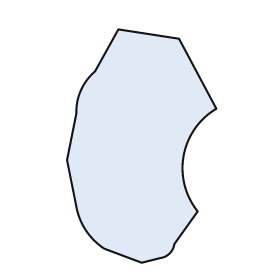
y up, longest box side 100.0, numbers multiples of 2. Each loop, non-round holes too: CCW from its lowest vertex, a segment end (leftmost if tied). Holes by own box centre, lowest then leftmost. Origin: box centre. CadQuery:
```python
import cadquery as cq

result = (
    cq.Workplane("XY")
    .moveTo(0.0, -50.0)
    .lineTo(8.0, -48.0)
    .threePointArc((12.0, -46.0), (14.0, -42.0))
    .lineTo(24.0, -28.0)
    .threePointArc((18.0, -4.0), (32.0, 16.0))
    .lineTo(16.0, 46.0)
    .lineTo(-10.0, 50.0)
    .lineTo(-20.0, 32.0)
    .threePointArc((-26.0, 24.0), (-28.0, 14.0))
    .lineTo(-32.0, -6.0)
    .lineTo(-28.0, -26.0)
    .threePointArc((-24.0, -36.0), (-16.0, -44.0))
    .close()
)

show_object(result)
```